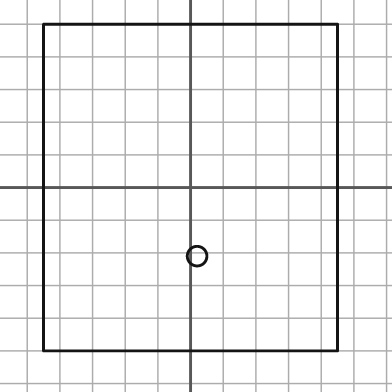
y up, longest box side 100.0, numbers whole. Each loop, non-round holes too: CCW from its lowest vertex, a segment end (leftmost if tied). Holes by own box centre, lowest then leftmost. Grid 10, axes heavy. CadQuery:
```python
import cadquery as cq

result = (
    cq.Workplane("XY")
    .moveTo(-45.0, -50.0)
    .lineTo(45.0, -50.0)
    .lineTo(45.0, 50.0)
    .lineTo(-45.0, 50.0)
    .close()
    .moveTo(2.0, -21.0)
    .circle(3.0)
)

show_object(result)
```